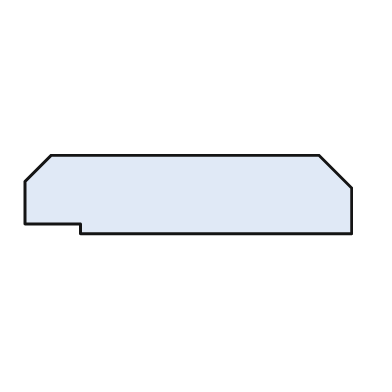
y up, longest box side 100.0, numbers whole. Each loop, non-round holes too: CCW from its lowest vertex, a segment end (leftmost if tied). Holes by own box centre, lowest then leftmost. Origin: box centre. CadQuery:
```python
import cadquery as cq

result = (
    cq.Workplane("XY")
    .moveTo(-33.0, -12.0)
    .lineTo(50.0, -12.0)
    .lineTo(50.0, 2.0)
    .lineTo(40.0, 12.0)
    .lineTo(-42.0, 12.0)
    .lineTo(-50.0, 4.0)
    .lineTo(-50.0, -9.0)
    .lineTo(-33.0, -9.0)
    .close()
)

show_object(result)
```